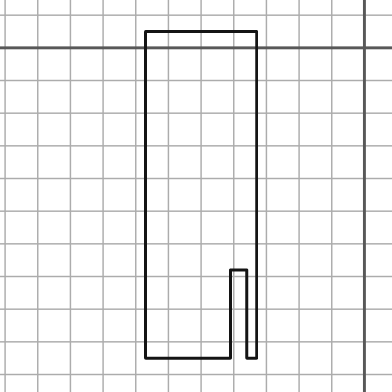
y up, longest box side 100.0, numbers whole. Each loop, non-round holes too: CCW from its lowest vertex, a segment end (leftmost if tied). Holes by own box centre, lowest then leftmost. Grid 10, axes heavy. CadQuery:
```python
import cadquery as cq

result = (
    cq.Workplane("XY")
    .moveTo(-67.0, -95.0)
    .lineTo(-41.0, -95.0)
    .lineTo(-41.0, -68.0)
    .lineTo(-36.0, -68.0)
    .lineTo(-36.0, -95.0)
    .lineTo(-33.0, -95.0)
    .lineTo(-33.0, 5.0)
    .lineTo(-67.0, 5.0)
    .close()
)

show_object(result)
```